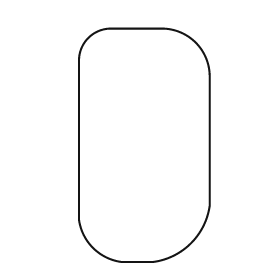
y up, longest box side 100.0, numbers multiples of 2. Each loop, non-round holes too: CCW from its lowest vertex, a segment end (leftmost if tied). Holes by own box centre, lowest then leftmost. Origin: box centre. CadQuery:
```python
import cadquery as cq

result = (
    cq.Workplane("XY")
    .moveTo(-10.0, -50.0)
    .lineTo(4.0, -50.0)
    .threePointArc((20.0, -42.0), (28.0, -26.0))
    .lineTo(28.0, 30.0)
    .threePointArc((22.0, 44.0), (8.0, 50.0))
    .lineTo(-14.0, 50.0)
    .threePointArc((-24.0, 46.0), (-28.0, 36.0))
    .lineTo(-28.0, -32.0)
    .threePointArc((-22.0, -44.0), (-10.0, -50.0))
    .close()
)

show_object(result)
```